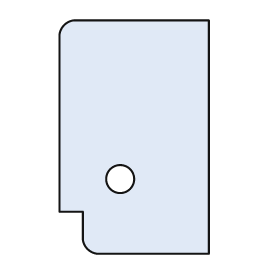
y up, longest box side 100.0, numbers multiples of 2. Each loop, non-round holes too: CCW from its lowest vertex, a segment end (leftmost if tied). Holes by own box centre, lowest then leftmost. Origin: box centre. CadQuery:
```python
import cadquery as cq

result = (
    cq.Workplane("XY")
    .moveTo(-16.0, -50.0)
    .lineTo(32.0, -50.0)
    .lineTo(32.0, 50.0)
    .lineTo(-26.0, 50.0)
    .threePointArc((-30.0, 48.0), (-32.0, 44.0))
    .lineTo(-32.0, -32.0)
    .lineTo(-22.0, -32.0)
    .lineTo(-22.0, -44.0)
    .threePointArc((-20.0, -48.0), (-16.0, -50.0))
    .close()
    .moveTo(-6.0, -18.0)
    .circle(6.0)
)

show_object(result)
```